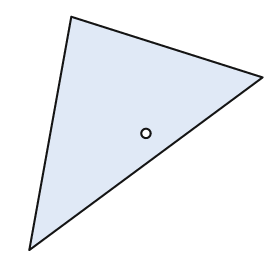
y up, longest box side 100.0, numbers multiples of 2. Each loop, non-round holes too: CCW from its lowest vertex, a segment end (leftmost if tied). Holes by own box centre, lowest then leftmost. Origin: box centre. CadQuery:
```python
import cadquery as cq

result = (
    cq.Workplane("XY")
    .moveTo(-50.0, -50.0)
    .lineTo(50.0, 24.0)
    .lineTo(-32.0, 50.0)
    .close()
    .moveTo(0.0, 0.0)
    .circle(2.0)
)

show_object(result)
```